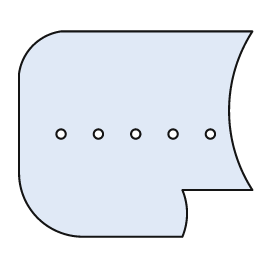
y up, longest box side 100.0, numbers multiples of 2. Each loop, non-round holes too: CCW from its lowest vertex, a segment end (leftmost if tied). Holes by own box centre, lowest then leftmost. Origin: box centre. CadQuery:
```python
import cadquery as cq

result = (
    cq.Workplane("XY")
    .moveTo(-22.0, -44.0)
    .lineTo(20.0, -44.0)
    .threePointArc((22.0, -34.0), (20.0, -24.0))
    .lineTo(50.0, -24.0)
    .threePointArc((40.0, 10.0), (50.0, 44.0))
    .lineTo(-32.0, 44.0)
    .threePointArc((-44.0, 38.0), (-50.0, 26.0))
    .lineTo(-50.0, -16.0)
    .threePointArc((-42.0, -36.0), (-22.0, -44.0))
    .close()
    .moveTo(-32.0, 0.0)
    .circle(2.0)
    .moveTo(-16.0, 0.0)
    .circle(2.0)
    .moveTo(0.0, 0.0)
    .circle(2.0)
    .moveTo(16.0, 0.0)
    .circle(2.0)
    .moveTo(32.0, 0.0)
    .circle(2.0)
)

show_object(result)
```